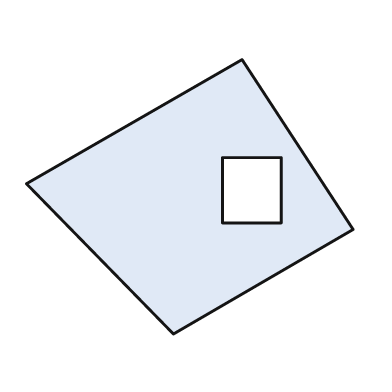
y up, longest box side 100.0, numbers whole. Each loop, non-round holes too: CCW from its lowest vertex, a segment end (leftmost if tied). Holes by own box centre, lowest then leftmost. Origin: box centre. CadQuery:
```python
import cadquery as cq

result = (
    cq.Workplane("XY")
    .moveTo(-5.0, -42.0)
    .lineTo(50.0, -10.0)
    .lineTo(16.0, 42.0)
    .lineTo(-50.0, 4.0)
    .close()
    .moveTo(10.0, -8.0)
    .lineTo(28.0, -8.0)
    .lineTo(28.0, 12.0)
    .lineTo(10.0, 12.0)
    .close()
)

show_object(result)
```